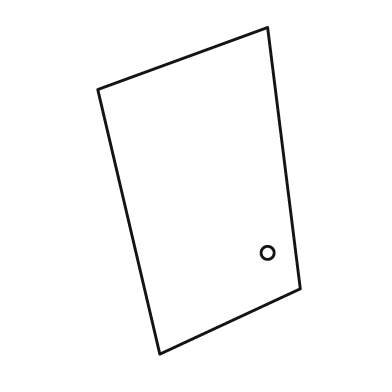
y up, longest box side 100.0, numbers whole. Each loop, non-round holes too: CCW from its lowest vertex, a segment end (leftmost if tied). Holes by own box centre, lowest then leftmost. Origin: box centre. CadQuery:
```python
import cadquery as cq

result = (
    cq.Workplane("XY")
    .moveTo(-12.0, -50.0)
    .lineTo(31.0, -30.0)
    .lineTo(21.0, 50.0)
    .lineTo(-31.0, 31.0)
    .close()
    .moveTo(21.0, -19.0)
    .circle(2.0)
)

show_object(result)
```